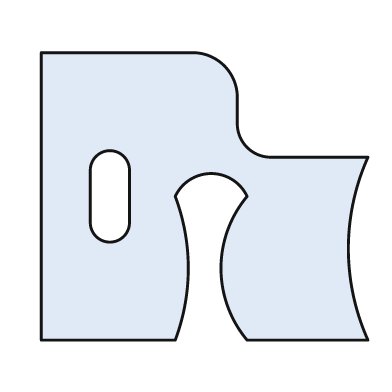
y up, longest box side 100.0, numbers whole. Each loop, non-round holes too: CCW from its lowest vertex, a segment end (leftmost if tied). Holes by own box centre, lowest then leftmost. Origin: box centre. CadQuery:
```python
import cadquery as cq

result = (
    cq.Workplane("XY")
    .moveTo(-50.0, -44.0)
    .lineTo(-9.0, -44.0)
    .threePointArc((-5.0, -22.0), (-9.0, 0.0))
    .threePointArc((2.0, 7.0), (13.0, 0.0))
    .threePointArc((5.0, -22.0), (13.0, -44.0))
    .lineTo(50.0, -44.0)
    .threePointArc((44.0, -16.0), (50.0, 12.0))
    .lineTo(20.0, 12.0)
    .threePointArc((13.0, 15.0), (10.0, 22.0))
    .lineTo(10.0, 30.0)
    .threePointArc((6.0, 40.0), (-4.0, 44.0))
    .lineTo(-50.0, 44.0)
    .close()
    .moveTo(-35.0, -8.0)
    .threePointArc((-29.0, -14.0), (-23.0, -8.0))
    .lineTo(-23.0, 8.0)
    .threePointArc((-29.0, 14.0), (-35.0, 8.0))
    .close()
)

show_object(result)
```